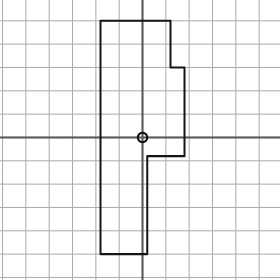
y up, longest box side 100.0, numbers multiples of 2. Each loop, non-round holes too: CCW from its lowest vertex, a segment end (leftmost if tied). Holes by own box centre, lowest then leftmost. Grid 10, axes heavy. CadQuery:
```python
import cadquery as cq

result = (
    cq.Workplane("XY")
    .moveTo(-18.0, -50.0)
    .lineTo(2.0, -50.0)
    .lineTo(2.0, -8.0)
    .lineTo(18.0, -8.0)
    .lineTo(18.0, 30.0)
    .lineTo(12.0, 30.0)
    .lineTo(12.0, 50.0)
    .lineTo(-18.0, 50.0)
    .close()
    .moveTo(0.0, 0.0)
    .circle(2.0)
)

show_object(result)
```